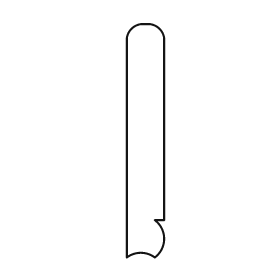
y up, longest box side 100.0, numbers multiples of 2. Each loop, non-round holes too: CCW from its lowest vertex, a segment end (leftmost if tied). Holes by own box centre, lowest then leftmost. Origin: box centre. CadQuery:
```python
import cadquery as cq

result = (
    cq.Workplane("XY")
    .moveTo(-8.0, -50.0)
    .threePointArc((-2.0, -48.0), (4.0, -50.0))
    .threePointArc((8.0, -42.0), (4.0, -34.0))
    .lineTo(8.0, -34.0)
    .lineTo(8.0, 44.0)
    .threePointArc((6.0, 48.0), (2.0, 50.0))
    .lineTo(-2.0, 50.0)
    .threePointArc((-6.0, 48.0), (-8.0, 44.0))
    .close()
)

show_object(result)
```